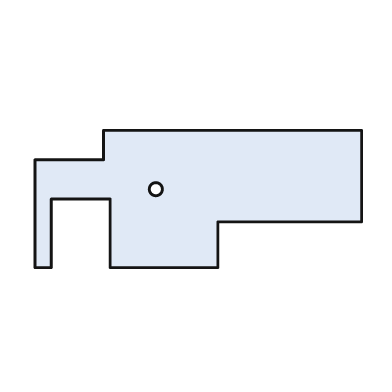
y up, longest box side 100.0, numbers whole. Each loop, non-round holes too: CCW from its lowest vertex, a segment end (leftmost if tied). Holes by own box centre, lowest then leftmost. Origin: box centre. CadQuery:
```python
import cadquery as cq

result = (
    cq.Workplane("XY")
    .moveTo(-50.0, -21.0)
    .lineTo(-45.0, -21.0)
    .lineTo(-45.0, 0.0)
    .lineTo(-27.0, 0.0)
    .lineTo(-27.0, -21.0)
    .lineTo(6.0, -21.0)
    .lineTo(6.0, -7.0)
    .lineTo(50.0, -7.0)
    .lineTo(50.0, 21.0)
    .lineTo(-29.0, 21.0)
    .lineTo(-29.0, 12.0)
    .lineTo(-50.0, 12.0)
    .close()
    .moveTo(-13.0, 3.0)
    .circle(2.0)
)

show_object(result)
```